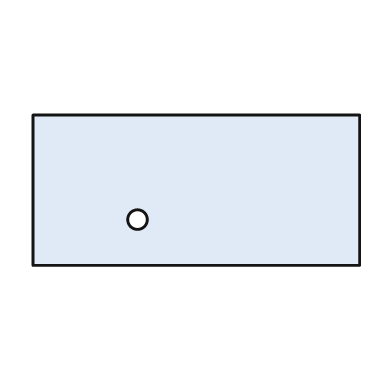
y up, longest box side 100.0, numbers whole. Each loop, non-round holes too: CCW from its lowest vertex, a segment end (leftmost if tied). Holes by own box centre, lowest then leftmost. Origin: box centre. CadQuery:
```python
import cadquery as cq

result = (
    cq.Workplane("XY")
    .moveTo(-50.0, -23.0)
    .lineTo(50.0, -23.0)
    .lineTo(50.0, 23.0)
    .lineTo(-50.0, 23.0)
    .close()
    .moveTo(-18.0, -9.0)
    .circle(3.0)
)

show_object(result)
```